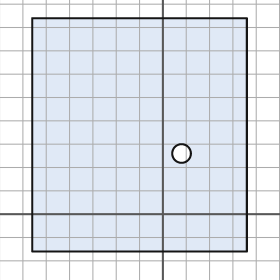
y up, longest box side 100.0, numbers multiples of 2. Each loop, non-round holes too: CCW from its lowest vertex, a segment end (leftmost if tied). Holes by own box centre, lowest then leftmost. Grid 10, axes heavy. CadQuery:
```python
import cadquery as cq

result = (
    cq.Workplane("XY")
    .moveTo(-56.0, -16.0)
    .lineTo(36.0, -16.0)
    .lineTo(36.0, 84.0)
    .lineTo(-56.0, 84.0)
    .close()
    .moveTo(8.0, 26.0)
    .circle(4.0)
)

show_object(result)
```